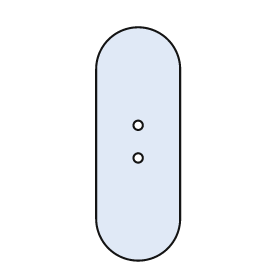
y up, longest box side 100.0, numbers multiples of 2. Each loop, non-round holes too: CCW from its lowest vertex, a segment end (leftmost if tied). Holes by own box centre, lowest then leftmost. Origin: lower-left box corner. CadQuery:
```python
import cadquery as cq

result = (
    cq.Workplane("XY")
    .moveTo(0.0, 18.0)
    .threePointArc((18.0, 0.0), (36.0, 18.0))
    .lineTo(36.0, 82.0)
    .threePointArc((18.0, 100.0), (0.0, 82.0))
    .close()
    .moveTo(18.0, 44.0)
    .circle(2.0)
    .moveTo(18.0, 58.0)
    .circle(2.0)
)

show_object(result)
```